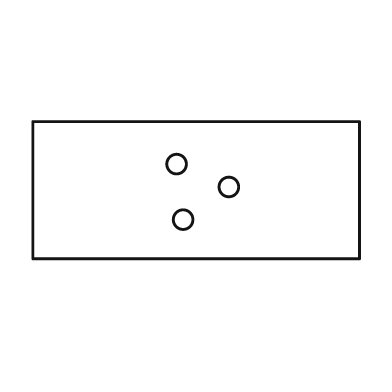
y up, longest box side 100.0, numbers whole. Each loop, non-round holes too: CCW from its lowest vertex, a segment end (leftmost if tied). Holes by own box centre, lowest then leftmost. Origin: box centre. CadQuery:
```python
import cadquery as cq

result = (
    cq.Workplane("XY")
    .moveTo(-50.0, -21.0)
    .lineTo(50.0, -21.0)
    .lineTo(50.0, 21.0)
    .lineTo(-50.0, 21.0)
    .close()
    .moveTo(-4.0, -9.0)
    .circle(3.0)
    .moveTo(10.0, 1.0)
    .circle(3.0)
    .moveTo(-6.0, 8.0)
    .circle(3.0)
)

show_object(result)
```